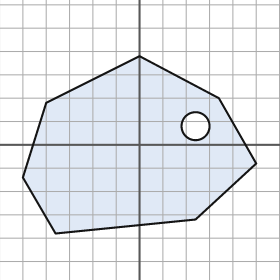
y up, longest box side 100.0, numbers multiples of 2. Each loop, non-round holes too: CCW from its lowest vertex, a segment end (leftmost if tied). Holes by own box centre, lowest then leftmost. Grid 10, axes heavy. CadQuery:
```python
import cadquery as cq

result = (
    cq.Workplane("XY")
    .moveTo(-36.0, -38.0)
    .lineTo(24.0, -32.0)
    .lineTo(50.0, -8.0)
    .lineTo(34.0, 20.0)
    .lineTo(0.0, 38.0)
    .lineTo(-40.0, 18.0)
    .lineTo(-50.0, -14.0)
    .close()
    .moveTo(24.0, 8.0)
    .circle(6.0)
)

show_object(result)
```